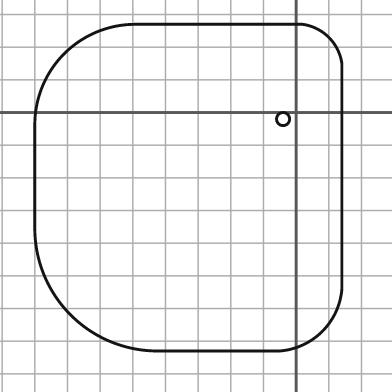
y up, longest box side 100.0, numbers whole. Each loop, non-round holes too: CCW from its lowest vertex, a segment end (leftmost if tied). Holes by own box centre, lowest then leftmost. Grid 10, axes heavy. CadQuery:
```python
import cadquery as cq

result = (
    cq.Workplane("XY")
    .moveTo(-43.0, -73.0)
    .lineTo(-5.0, -73.0)
    .threePointArc((8.0, -67.0), (14.0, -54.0))
    .lineTo(14.0, 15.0)
    .threePointArc((10.0, 23.0), (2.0, 27.0))
    .lineTo(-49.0, 27.0)
    .threePointArc((-71.0, 18.0), (-80.0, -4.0))
    .lineTo(-80.0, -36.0)
    .threePointArc((-69.0, -62.0), (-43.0, -73.0))
    .close()
    .moveTo(-4.0, -2.0)
    .circle(2.0)
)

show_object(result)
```